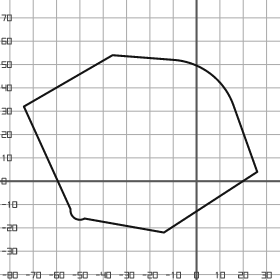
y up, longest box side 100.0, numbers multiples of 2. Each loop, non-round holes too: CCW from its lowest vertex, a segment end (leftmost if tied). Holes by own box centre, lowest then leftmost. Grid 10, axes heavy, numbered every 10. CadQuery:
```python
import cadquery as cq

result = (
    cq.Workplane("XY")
    .moveTo(-14.0, -22.0)
    .lineTo(26.0, 4.0)
    .lineTo(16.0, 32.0)
    .threePointArc((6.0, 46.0), (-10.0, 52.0))
    .lineTo(-36.0, 54.0)
    .lineTo(-74.0, 32.0)
    .lineTo(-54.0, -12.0)
    .threePointArc((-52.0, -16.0), (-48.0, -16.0))
    .close()
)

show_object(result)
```